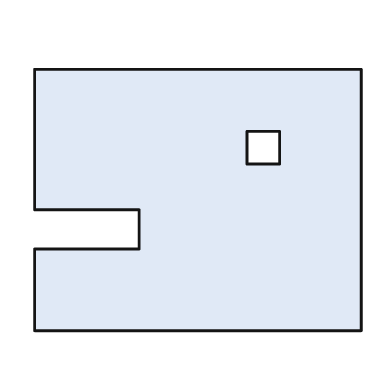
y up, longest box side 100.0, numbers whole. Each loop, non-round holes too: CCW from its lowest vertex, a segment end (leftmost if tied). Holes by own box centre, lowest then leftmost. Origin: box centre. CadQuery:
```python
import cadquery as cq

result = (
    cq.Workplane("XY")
    .moveTo(-50.0, -40.0)
    .lineTo(50.0, -40.0)
    .lineTo(50.0, 40.0)
    .lineTo(-50.0, 40.0)
    .lineTo(-50.0, -3.0)
    .lineTo(-18.0, -3.0)
    .lineTo(-18.0, -15.0)
    .lineTo(-50.0, -15.0)
    .close()
    .moveTo(15.0, 11.0)
    .lineTo(25.0, 11.0)
    .lineTo(25.0, 21.0)
    .lineTo(15.0, 21.0)
    .close()
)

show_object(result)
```